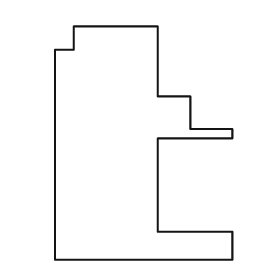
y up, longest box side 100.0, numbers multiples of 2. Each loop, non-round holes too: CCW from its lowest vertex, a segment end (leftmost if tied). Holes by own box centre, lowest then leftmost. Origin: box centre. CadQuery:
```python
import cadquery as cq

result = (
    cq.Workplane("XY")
    .moveTo(-38.0, -50.0)
    .lineTo(38.0, -50.0)
    .lineTo(38.0, -38.0)
    .lineTo(6.0, -38.0)
    .lineTo(6.0, 2.0)
    .lineTo(38.0, 2.0)
    .lineTo(38.0, 6.0)
    .lineTo(20.0, 6.0)
    .lineTo(20.0, 20.0)
    .lineTo(6.0, 20.0)
    .lineTo(6.0, 50.0)
    .lineTo(-30.0, 50.0)
    .lineTo(-30.0, 40.0)
    .lineTo(-38.0, 40.0)
    .close()
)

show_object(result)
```